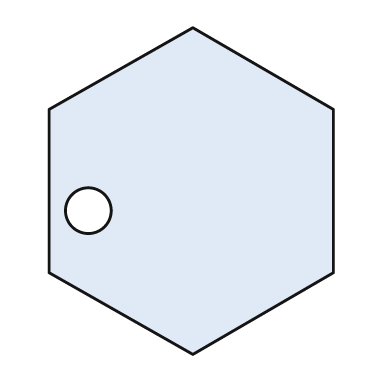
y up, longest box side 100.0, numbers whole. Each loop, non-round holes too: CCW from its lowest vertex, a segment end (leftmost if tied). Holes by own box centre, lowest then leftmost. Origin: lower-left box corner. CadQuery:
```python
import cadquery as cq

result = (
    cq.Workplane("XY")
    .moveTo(44.0, 0.0)
    .lineTo(87.0, 25.0)
    .lineTo(87.0, 75.0)
    .lineTo(44.0, 100.0)
    .lineTo(0.0, 75.0)
    .lineTo(0.0, 25.0)
    .close()
    .moveTo(12.0, 44.0)
    .circle(7.0)
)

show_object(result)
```